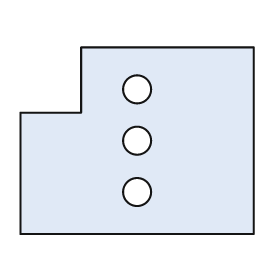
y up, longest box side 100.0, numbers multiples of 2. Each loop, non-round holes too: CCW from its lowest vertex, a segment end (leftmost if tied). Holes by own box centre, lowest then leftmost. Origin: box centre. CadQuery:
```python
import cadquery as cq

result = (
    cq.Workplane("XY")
    .moveTo(-50.0, -40.0)
    .lineTo(50.0, -40.0)
    .lineTo(50.0, 40.0)
    .lineTo(-24.0, 40.0)
    .lineTo(-24.0, 12.0)
    .lineTo(-50.0, 12.0)
    .close()
    .moveTo(0.0, -22.0)
    .circle(6.0)
    .moveTo(0.0, 0.0)
    .circle(6.0)
    .moveTo(0.0, 22.0)
    .circle(6.0)
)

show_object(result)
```